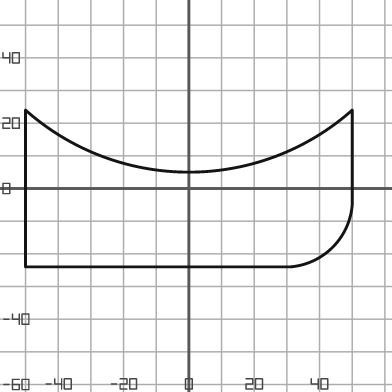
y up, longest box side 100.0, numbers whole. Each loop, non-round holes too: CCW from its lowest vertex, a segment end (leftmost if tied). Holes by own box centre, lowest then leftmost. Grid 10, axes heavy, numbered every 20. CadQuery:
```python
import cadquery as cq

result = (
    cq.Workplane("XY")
    .moveTo(-50.0, -24.0)
    .lineTo(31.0, -24.0)
    .threePointArc((44.0, -18.0), (50.0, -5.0))
    .lineTo(50.0, 24.0)
    .threePointArc((0.0, 5.0), (-50.0, 24.0))
    .close()
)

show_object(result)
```